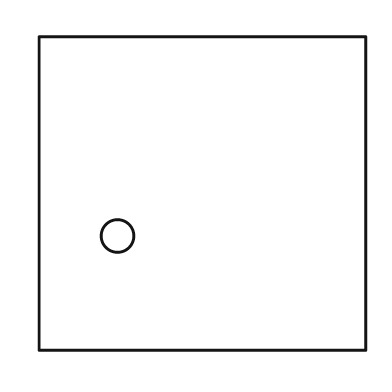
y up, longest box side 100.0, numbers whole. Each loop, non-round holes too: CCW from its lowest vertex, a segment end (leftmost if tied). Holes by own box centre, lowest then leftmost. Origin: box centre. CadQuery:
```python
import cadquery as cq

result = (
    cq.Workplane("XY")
    .moveTo(-50.0, -48.0)
    .lineTo(50.0, -48.0)
    .lineTo(50.0, 48.0)
    .lineTo(-50.0, 48.0)
    .close()
    .moveTo(-26.0, -13.0)
    .circle(5.0)
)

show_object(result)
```